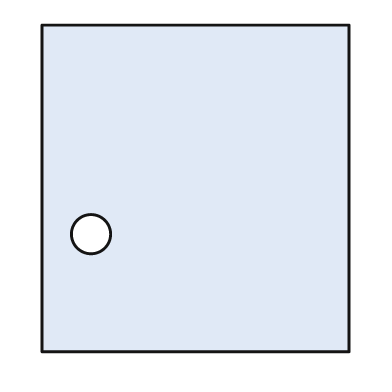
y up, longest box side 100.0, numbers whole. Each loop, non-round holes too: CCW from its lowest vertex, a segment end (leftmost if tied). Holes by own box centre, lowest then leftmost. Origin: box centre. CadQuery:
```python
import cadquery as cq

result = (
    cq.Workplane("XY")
    .moveTo(-47.0, -50.0)
    .lineTo(47.0, -50.0)
    .lineTo(47.0, 50.0)
    .lineTo(-47.0, 50.0)
    .close()
    .moveTo(-32.0, -14.0)
    .circle(6.0)
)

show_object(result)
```